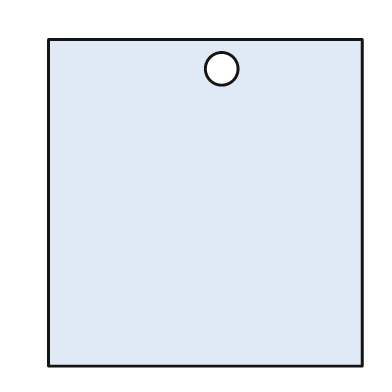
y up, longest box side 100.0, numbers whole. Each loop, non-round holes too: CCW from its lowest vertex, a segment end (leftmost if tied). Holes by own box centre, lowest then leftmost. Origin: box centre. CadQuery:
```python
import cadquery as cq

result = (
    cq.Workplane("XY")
    .moveTo(-48.0, -50.0)
    .lineTo(48.0, -50.0)
    .lineTo(48.0, 50.0)
    .lineTo(-48.0, 50.0)
    .close()
    .moveTo(5.0, 41.0)
    .circle(5.0)
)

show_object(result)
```